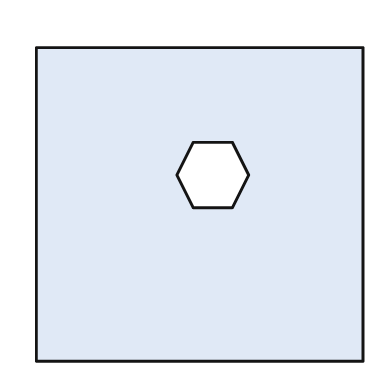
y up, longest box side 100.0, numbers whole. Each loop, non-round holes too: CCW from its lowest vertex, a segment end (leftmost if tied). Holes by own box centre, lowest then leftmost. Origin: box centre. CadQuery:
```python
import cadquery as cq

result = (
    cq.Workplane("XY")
    .moveTo(-50.0, -48.0)
    .lineTo(50.0, -48.0)
    .lineTo(50.0, 48.0)
    .lineTo(-50.0, 48.0)
    .close()
    .moveTo(-2.0, -1.0)
    .lineTo(10.0, -1.0)
    .lineTo(15.0, 9.0)
    .lineTo(10.0, 19.0)
    .lineTo(-2.0, 19.0)
    .lineTo(-7.0, 9.0)
    .close()
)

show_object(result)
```